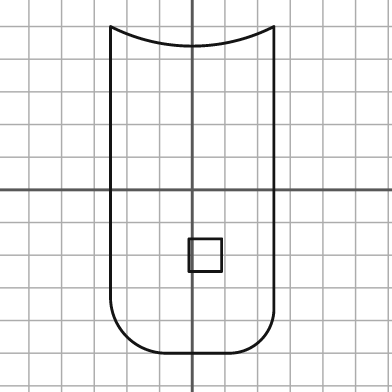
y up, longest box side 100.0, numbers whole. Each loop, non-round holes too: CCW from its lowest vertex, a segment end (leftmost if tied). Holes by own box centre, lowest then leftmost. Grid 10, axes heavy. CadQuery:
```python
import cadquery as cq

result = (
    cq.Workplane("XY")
    .moveTo(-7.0, -50.0)
    .lineTo(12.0, -50.0)
    .threePointArc((21.0, -46.0), (25.0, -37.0))
    .lineTo(25.0, 50.0)
    .threePointArc((0.0, 44.0), (-25.0, 50.0))
    .lineTo(-25.0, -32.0)
    .threePointArc((-20.0, -45.0), (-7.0, -50.0))
    .close()
    .moveTo(-1.0, -25.0)
    .lineTo(9.0, -25.0)
    .lineTo(9.0, -15.0)
    .lineTo(-1.0, -15.0)
    .close()
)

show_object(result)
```